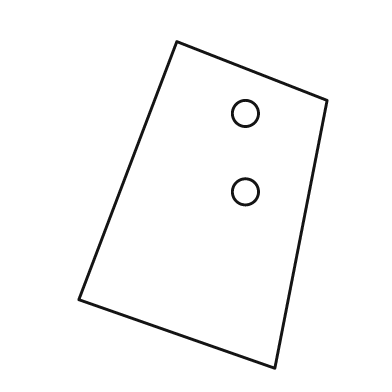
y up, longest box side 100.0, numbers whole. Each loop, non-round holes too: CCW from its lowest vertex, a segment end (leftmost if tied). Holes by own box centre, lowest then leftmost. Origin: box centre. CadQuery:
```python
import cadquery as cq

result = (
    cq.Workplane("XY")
    .moveTo(22.0, -50.0)
    .lineTo(38.0, 32.0)
    .lineTo(-8.0, 50.0)
    .lineTo(-38.0, -29.0)
    .close()
    .moveTo(13.0, 4.0)
    .circle(4.0)
    .moveTo(13.0, 28.0)
    .circle(4.0)
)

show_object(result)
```